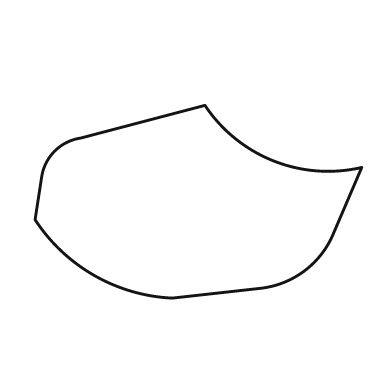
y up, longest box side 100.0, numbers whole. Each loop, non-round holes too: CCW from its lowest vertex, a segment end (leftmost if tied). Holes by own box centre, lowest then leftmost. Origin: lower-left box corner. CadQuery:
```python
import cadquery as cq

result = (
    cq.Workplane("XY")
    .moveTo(42.0, 0.0)
    .lineTo(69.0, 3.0)
    .threePointArc((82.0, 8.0), (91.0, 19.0))
    .lineTo(100.0, 40.0)
    .threePointArc((73.0, 42.0), (52.0, 59.0))
    .lineTo(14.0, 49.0)
    .threePointArc((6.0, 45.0), (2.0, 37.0))
    .lineTo(0.0, 24.0)
    .threePointArc((18.0, 7.0), (42.0, 0.0))
    .close()
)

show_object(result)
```